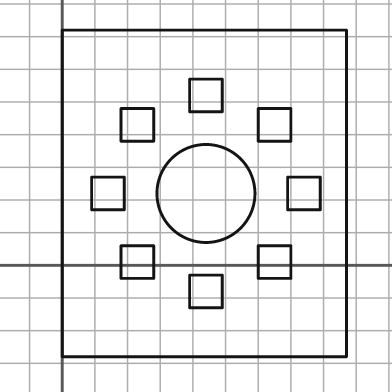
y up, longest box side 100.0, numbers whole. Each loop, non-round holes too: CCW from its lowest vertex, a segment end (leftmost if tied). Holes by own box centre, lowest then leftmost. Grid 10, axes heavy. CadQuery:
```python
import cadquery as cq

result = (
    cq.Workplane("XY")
    .moveTo(0.0, -28.0)
    .lineTo(87.0, -28.0)
    .lineTo(87.0, 72.0)
    .lineTo(0.0, 72.0)
    .close()
    .moveTo(39.0, -13.0)
    .lineTo(49.0, -13.0)
    .lineTo(49.0, -3.0)
    .lineTo(39.0, -3.0)
    .close()
    .moveTo(18.0, -4.0)
    .lineTo(28.0, -4.0)
    .lineTo(28.0, 6.0)
    .lineTo(18.0, 6.0)
    .close()
    .moveTo(60.0, -4.0)
    .lineTo(70.0, -4.0)
    .lineTo(70.0, 6.0)
    .lineTo(60.0, 6.0)
    .close()
    .moveTo(9.0, 17.0)
    .lineTo(19.0, 17.0)
    .lineTo(19.0, 27.0)
    .lineTo(9.0, 27.0)
    .close()
    .moveTo(44.0, 22.0)
    .circle(15.0)
    .moveTo(69.0, 17.0)
    .lineTo(79.0, 17.0)
    .lineTo(79.0, 27.0)
    .lineTo(69.0, 27.0)
    .close()
    .moveTo(18.0, 38.0)
    .lineTo(28.0, 38.0)
    .lineTo(28.0, 48.0)
    .lineTo(18.0, 48.0)
    .close()
    .moveTo(60.0, 38.0)
    .lineTo(70.0, 38.0)
    .lineTo(70.0, 48.0)
    .lineTo(60.0, 48.0)
    .close()
    .moveTo(39.0, 47.0)
    .lineTo(49.0, 47.0)
    .lineTo(49.0, 57.0)
    .lineTo(39.0, 57.0)
    .close()
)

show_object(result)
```